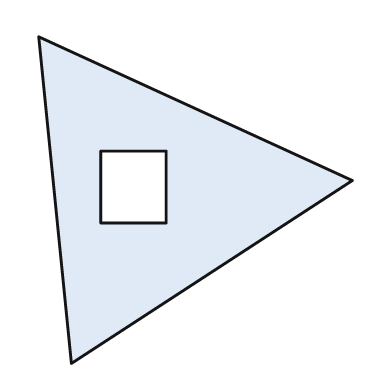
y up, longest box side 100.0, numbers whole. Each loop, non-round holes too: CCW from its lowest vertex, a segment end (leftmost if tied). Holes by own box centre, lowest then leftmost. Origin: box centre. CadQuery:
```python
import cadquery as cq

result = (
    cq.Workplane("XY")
    .moveTo(-38.0, -50.0)
    .lineTo(48.0, 6.0)
    .lineTo(-48.0, 50.0)
    .close()
    .moveTo(-29.0, -7.0)
    .lineTo(-9.0, -7.0)
    .lineTo(-9.0, 15.0)
    .lineTo(-29.0, 15.0)
    .close()
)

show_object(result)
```